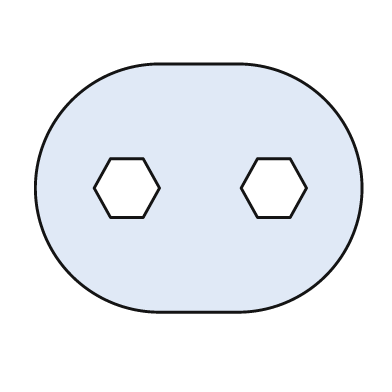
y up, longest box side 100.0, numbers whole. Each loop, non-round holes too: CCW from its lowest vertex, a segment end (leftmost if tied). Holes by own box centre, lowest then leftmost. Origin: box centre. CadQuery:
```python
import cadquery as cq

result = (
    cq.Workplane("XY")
    .moveTo(-12.0, -38.0)
    .lineTo(12.0, -38.0)
    .threePointArc((50.0, 0.0), (12.0, 38.0))
    .lineTo(-12.0, 38.0)
    .threePointArc((-50.0, 0.0), (-12.0, -38.0))
    .close()
    .moveTo(-27.0, -9.0)
    .lineTo(-17.0, -9.0)
    .lineTo(-12.0, 0.0)
    .lineTo(-17.0, 9.0)
    .lineTo(-27.0, 9.0)
    .lineTo(-32.0, 0.0)
    .close()
    .moveTo(18.0, -9.0)
    .lineTo(28.0, -9.0)
    .lineTo(33.0, 0.0)
    .lineTo(28.0, 9.0)
    .lineTo(18.0, 9.0)
    .lineTo(13.0, 0.0)
    .close()
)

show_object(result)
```